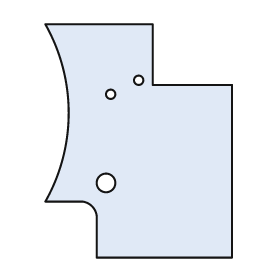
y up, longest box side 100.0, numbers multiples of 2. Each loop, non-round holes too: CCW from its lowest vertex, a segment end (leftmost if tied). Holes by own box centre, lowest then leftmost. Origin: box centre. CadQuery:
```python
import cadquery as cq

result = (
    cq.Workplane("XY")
    .moveTo(-18.0, -50.0)
    .lineTo(40.0, -50.0)
    .lineTo(40.0, 24.0)
    .lineTo(6.0, 24.0)
    .lineTo(6.0, 50.0)
    .lineTo(-40.0, 50.0)
    .threePointArc((-30.0, 12.0), (-40.0, -26.0))
    .lineTo(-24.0, -26.0)
    .threePointArc((-20.0, -28.0), (-18.0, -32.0))
    .close()
    .moveTo(-14.0, -18.0)
    .circle(4.0)
    .moveTo(-12.0, 20.0)
    .circle(2.0)
    .moveTo(0.0, 26.0)
    .circle(2.0)
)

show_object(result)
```